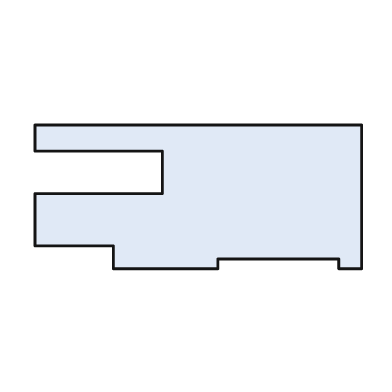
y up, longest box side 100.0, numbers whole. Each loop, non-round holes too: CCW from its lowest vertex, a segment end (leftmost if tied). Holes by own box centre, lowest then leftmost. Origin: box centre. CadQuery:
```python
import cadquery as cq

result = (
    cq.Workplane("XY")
    .moveTo(-26.0, -22.0)
    .lineTo(6.0, -22.0)
    .lineTo(6.0, -19.0)
    .lineTo(43.0, -19.0)
    .lineTo(43.0, -22.0)
    .lineTo(50.0, -22.0)
    .lineTo(50.0, 22.0)
    .lineTo(-50.0, 22.0)
    .lineTo(-50.0, 14.0)
    .lineTo(-11.0, 14.0)
    .lineTo(-11.0, 1.0)
    .lineTo(-50.0, 1.0)
    .lineTo(-50.0, -15.0)
    .lineTo(-26.0, -15.0)
    .close()
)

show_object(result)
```